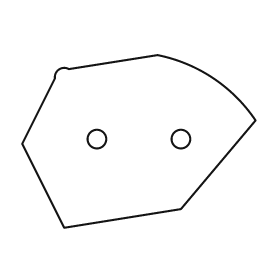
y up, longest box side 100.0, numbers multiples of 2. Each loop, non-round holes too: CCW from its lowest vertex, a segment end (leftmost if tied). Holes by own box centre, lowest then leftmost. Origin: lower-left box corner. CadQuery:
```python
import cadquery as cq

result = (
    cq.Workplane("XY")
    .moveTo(18.0, 0.0)
    .lineTo(68.0, 8.0)
    .lineTo(100.0, 46.0)
    .threePointArc((82.0, 64.0), (58.0, 74.0))
    .lineTo(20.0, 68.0)
    .threePointArc((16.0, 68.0), (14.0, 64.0))
    .lineTo(0.0, 36.0)
    .close()
    .moveTo(32.0, 38.0)
    .circle(4.0)
    .moveTo(68.0, 38.0)
    .circle(4.0)
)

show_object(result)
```